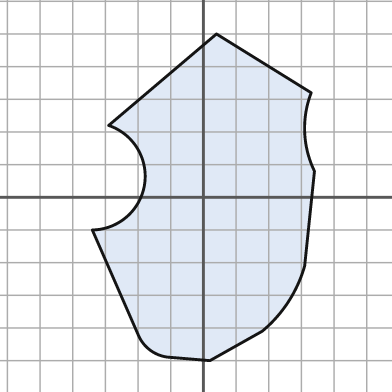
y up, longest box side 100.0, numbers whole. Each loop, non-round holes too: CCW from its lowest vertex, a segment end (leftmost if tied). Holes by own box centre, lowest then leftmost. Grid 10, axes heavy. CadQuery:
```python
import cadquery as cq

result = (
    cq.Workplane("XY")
    .moveTo(2.0, -50.0)
    .lineTo(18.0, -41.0)
    .threePointArc((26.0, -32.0), (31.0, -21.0))
    .lineTo(34.0, 8.0)
    .threePointArc((31.0, 20.0), (33.0, 32.0))
    .lineTo(4.0, 50.0)
    .lineTo(-29.0, 22.0)
    .threePointArc((-18.0, 4.0), (-34.0, -10.0))
    .lineTo(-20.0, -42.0)
    .threePointArc((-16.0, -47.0), (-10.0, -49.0))
    .close()
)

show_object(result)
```